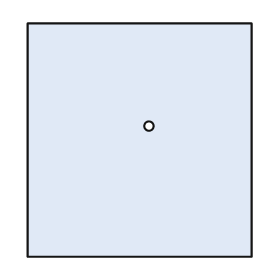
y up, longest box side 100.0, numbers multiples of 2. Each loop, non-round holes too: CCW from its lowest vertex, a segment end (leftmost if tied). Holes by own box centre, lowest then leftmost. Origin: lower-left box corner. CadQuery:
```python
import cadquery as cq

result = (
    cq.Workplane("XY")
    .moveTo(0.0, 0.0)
    .lineTo(96.0, 0.0)
    .lineTo(96.0, 100.0)
    .lineTo(0.0, 100.0)
    .close()
    .moveTo(52.0, 56.0)
    .circle(2.0)
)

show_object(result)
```